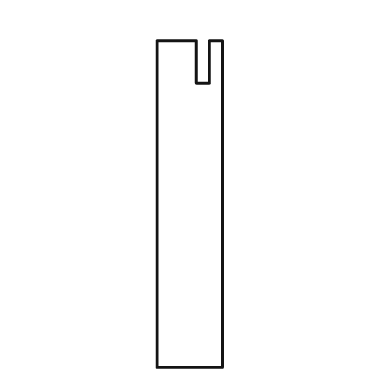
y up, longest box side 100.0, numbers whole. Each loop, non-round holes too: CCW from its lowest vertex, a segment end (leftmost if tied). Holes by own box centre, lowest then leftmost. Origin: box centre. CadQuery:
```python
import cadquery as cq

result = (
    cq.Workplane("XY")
    .moveTo(-10.0, -50.0)
    .lineTo(10.0, -50.0)
    .lineTo(10.0, 50.0)
    .lineTo(6.0, 50.0)
    .lineTo(6.0, 37.0)
    .lineTo(2.0, 37.0)
    .lineTo(2.0, 50.0)
    .lineTo(-10.0, 50.0)
    .close()
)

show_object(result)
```